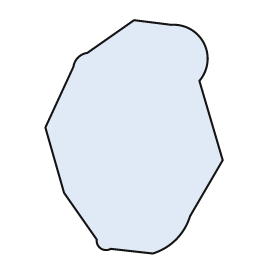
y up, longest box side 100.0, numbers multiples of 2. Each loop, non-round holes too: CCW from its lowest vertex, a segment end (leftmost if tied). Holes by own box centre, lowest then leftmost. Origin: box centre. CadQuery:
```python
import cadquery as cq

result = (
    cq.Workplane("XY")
    .moveTo(8.0, -50.0)
    .threePointArc((18.0, -44.0), (24.0, -34.0))
    .lineTo(38.0, -10.0)
    .lineTo(28.0, 24.0)
    .threePointArc((30.0, 40.0), (16.0, 48.0))
    .lineTo(0.0, 50.0)
    .lineTo(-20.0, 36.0)
    .threePointArc((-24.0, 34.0), (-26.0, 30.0))
    .lineTo(-38.0, 4.0)
    .lineTo(-30.0, -24.0)
    .lineTo(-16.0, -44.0)
    .threePointArc((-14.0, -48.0), (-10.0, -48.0))
    .close()
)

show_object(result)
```